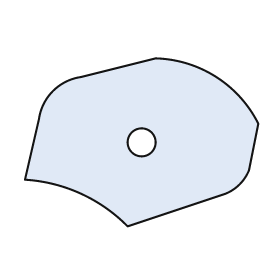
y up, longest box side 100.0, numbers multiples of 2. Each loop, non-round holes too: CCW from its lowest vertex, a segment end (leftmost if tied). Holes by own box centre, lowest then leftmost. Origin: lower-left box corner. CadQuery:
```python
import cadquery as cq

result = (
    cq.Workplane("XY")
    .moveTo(44.0, 0.0)
    .lineTo(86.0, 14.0)
    .threePointArc((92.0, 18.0), (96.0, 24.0))
    .lineTo(100.0, 44.0)
    .threePointArc((82.0, 64.0), (56.0, 72.0))
    .lineTo(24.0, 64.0)
    .threePointArc((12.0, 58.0), (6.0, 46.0))
    .lineTo(0.0, 20.0)
    .threePointArc((24.0, 14.0), (44.0, 0.0))
    .close()
    .moveTo(50.0, 36.0)
    .circle(6.0)
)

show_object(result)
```